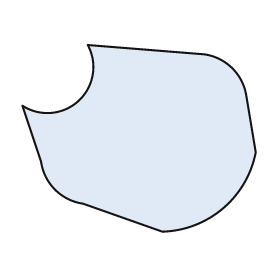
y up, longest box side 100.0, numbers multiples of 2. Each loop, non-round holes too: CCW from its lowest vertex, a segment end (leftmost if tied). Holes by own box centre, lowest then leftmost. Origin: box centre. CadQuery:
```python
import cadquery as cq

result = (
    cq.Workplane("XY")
    .moveTo(10.0, -40.0)
    .threePointArc((36.0, -30.0), (50.0, -6.0))
    .lineTo(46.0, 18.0)
    .threePointArc((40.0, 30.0), (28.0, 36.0))
    .lineTo(-22.0, 40.0)
    .threePointArc((-26.0, 16.0), (-50.0, 14.0))
    .lineTo(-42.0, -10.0)
    .threePointArc((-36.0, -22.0), (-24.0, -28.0))
    .close()
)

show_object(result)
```